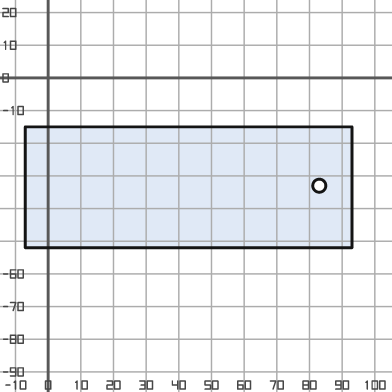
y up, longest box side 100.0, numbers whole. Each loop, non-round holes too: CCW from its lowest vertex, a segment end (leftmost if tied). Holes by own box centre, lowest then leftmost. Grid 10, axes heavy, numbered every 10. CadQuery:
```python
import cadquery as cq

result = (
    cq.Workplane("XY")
    .moveTo(-7.0, -52.0)
    .lineTo(93.0, -52.0)
    .lineTo(93.0, -15.0)
    .lineTo(-7.0, -15.0)
    .close()
    .moveTo(83.0, -33.0)
    .circle(2.0)
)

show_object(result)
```